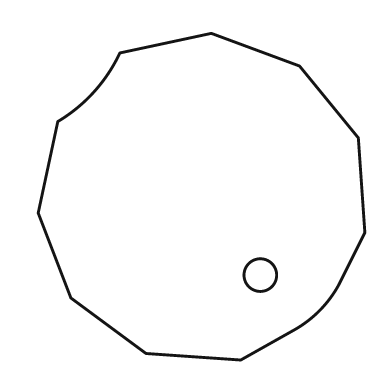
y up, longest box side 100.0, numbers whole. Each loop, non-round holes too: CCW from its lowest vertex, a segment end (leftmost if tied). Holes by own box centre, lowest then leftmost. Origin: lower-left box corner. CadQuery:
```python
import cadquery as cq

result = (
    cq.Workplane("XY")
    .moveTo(62.0, 0.0)
    .lineTo(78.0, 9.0)
    .threePointArc((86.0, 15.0), (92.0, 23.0))
    .lineTo(100.0, 39.0)
    .lineTo(98.0, 68.0)
    .lineTo(80.0, 90.0)
    .lineTo(53.0, 100.0)
    .lineTo(25.0, 94.0)
    .threePointArc((17.0, 82.0), (6.0, 73.0))
    .lineTo(0.0, 45.0)
    .lineTo(10.0, 19.0)
    .lineTo(33.0, 2.0)
    .close()
    .moveTo(68.0, 26.0)
    .circle(5.0)
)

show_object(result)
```